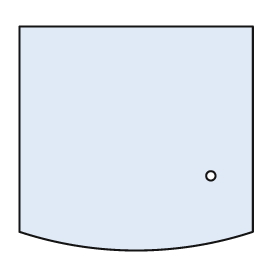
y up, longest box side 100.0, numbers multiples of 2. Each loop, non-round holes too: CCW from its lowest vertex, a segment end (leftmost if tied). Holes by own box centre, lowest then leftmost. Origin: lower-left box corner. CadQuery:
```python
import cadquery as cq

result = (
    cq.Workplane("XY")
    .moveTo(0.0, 8.0)
    .threePointArc((50.0, 0.0), (100.0, 8.0))
    .lineTo(100.0, 96.0)
    .lineTo(0.0, 96.0)
    .close()
    .moveTo(82.0, 32.0)
    .circle(2.0)
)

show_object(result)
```